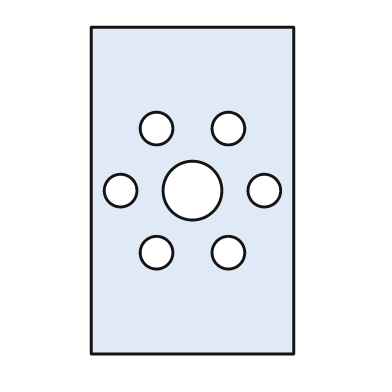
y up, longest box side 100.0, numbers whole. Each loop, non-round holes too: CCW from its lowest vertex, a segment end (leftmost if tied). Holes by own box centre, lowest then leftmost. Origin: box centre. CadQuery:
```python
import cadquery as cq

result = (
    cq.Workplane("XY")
    .moveTo(-31.0, -50.0)
    .lineTo(31.0, -50.0)
    .lineTo(31.0, 50.0)
    .lineTo(-31.0, 50.0)
    .close()
    .moveTo(-11.0, -19.0)
    .circle(5.0)
    .moveTo(11.0, -19.0)
    .circle(5.0)
    .moveTo(-22.0, 0.0)
    .circle(5.0)
    .moveTo(0.0, 0.0)
    .circle(9.0)
    .moveTo(22.0, 0.0)
    .circle(5.0)
    .moveTo(-11.0, 19.0)
    .circle(5.0)
    .moveTo(11.0, 19.0)
    .circle(5.0)
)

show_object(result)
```